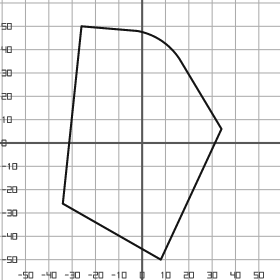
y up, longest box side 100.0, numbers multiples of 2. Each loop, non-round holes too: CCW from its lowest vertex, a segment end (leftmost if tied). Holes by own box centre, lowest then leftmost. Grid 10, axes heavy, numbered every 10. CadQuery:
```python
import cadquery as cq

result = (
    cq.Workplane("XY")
    .moveTo(8.0, -50.0)
    .lineTo(34.0, 6.0)
    .lineTo(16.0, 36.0)
    .threePointArc((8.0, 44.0), (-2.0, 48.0))
    .lineTo(-26.0, 50.0)
    .lineTo(-34.0, -26.0)
    .close()
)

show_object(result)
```